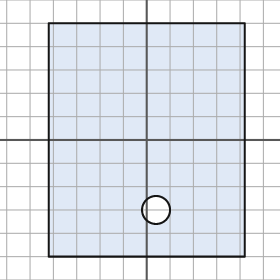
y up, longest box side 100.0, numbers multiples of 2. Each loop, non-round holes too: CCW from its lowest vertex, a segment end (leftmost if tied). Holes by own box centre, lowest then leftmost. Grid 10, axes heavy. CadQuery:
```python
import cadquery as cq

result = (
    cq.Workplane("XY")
    .moveTo(-42.0, -50.0)
    .lineTo(42.0, -50.0)
    .lineTo(42.0, 50.0)
    .lineTo(-42.0, 50.0)
    .close()
    .moveTo(4.0, -30.0)
    .circle(6.0)
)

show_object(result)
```